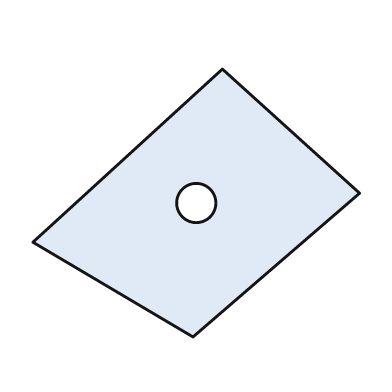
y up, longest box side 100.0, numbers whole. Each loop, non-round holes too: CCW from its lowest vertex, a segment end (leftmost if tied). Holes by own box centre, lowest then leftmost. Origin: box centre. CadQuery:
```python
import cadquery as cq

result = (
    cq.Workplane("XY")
    .moveTo(-1.0, -41.0)
    .lineTo(50.0, 3.0)
    .lineTo(8.0, 41.0)
    .lineTo(-50.0, -12.0)
    .close()
    .moveTo(0.0, 0.0)
    .circle(6.0)
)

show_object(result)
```